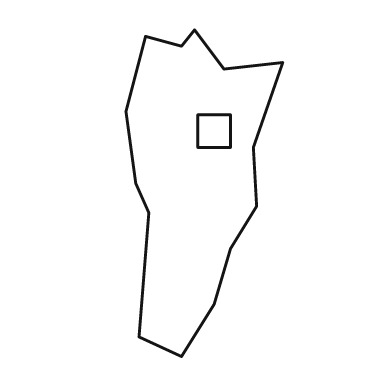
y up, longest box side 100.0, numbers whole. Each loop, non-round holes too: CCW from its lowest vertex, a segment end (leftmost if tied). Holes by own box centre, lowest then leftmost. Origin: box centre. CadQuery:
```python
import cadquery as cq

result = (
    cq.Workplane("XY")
    .moveTo(-7.0, -50.0)
    .lineTo(3.0, -34.0)
    .lineTo(8.0, -17.0)
    .lineTo(16.0, -4.0)
    .lineTo(15.0, 14.0)
    .lineTo(24.0, 40.0)
    .lineTo(6.0, 38.0)
    .lineTo(-3.0, 50.0)
    .lineTo(-7.0, 45.0)
    .lineTo(-18.0, 48.0)
    .lineTo(-24.0, 25.0)
    .lineTo(-21.0, 3.0)
    .lineTo(-17.0, -6.0)
    .lineTo(-20.0, -44.0)
    .close()
    .moveTo(-2.0, 14.0)
    .lineTo(8.0, 14.0)
    .lineTo(8.0, 24.0)
    .lineTo(-2.0, 24.0)
    .close()
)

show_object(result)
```